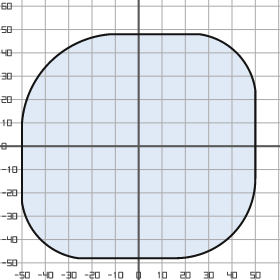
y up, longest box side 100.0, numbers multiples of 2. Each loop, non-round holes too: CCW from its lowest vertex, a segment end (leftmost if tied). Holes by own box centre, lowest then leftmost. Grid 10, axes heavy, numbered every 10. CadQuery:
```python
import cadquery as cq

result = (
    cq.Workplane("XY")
    .moveTo(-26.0, -48.0)
    .lineTo(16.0, -48.0)
    .threePointArc((40.0, -38.0), (50.0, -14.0))
    .lineTo(50.0, 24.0)
    .threePointArc((42.0, 40.0), (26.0, 48.0))
    .lineTo(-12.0, 48.0)
    .threePointArc((-38.0, 36.0), (-50.0, 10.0))
    .lineTo(-50.0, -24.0)
    .threePointArc((-42.0, -40.0), (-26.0, -48.0))
    .close()
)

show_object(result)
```